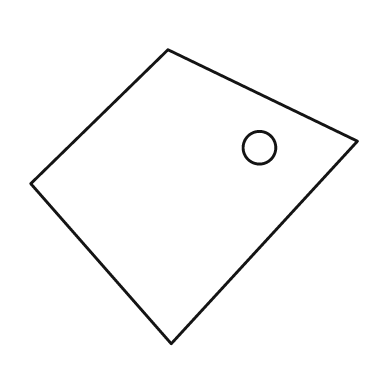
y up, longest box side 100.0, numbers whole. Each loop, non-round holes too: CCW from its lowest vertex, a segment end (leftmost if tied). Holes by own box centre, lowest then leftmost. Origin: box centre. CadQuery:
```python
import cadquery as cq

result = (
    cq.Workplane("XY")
    .moveTo(-7.0, -45.0)
    .lineTo(50.0, 17.0)
    .lineTo(-8.0, 45.0)
    .lineTo(-50.0, 4.0)
    .close()
    .moveTo(20.0, 15.0)
    .circle(5.0)
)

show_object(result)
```